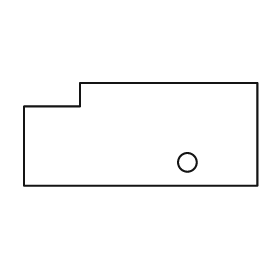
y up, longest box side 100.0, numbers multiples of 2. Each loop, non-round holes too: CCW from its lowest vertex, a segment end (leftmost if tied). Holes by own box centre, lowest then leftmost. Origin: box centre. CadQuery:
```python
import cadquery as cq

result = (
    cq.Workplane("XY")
    .moveTo(-50.0, -22.0)
    .lineTo(50.0, -22.0)
    .lineTo(50.0, 22.0)
    .lineTo(-26.0, 22.0)
    .lineTo(-26.0, 12.0)
    .lineTo(-50.0, 12.0)
    .close()
    .moveTo(20.0, -12.0)
    .circle(4.0)
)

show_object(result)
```